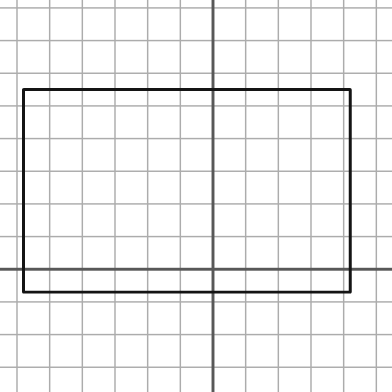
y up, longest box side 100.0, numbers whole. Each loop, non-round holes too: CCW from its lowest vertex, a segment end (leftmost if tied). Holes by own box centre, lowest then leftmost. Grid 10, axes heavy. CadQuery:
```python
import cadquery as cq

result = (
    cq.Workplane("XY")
    .moveTo(-58.0, -7.0)
    .lineTo(42.0, -7.0)
    .lineTo(42.0, 55.0)
    .lineTo(-58.0, 55.0)
    .close()
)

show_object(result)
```